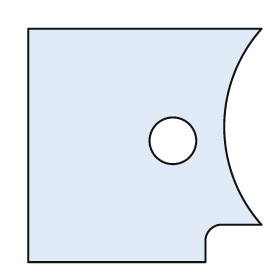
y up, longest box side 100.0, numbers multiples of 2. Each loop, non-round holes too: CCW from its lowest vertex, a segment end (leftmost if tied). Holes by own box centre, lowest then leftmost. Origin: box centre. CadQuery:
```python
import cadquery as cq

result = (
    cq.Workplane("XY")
    .moveTo(-50.0, -50.0)
    .lineTo(26.0, -50.0)
    .lineTo(26.0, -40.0)
    .threePointArc((28.0, -36.0), (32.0, -34.0))
    .lineTo(50.0, -34.0)
    .threePointArc((34.0, 8.0), (50.0, 50.0))
    .lineTo(-50.0, 50.0)
    .close()
    .moveTo(12.0, 2.0)
    .circle(10.0)
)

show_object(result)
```